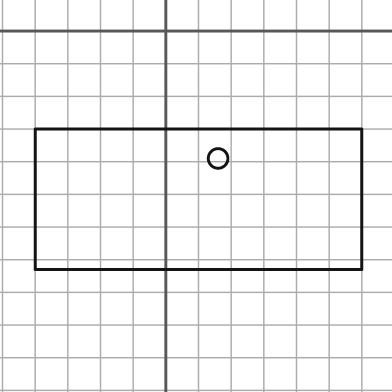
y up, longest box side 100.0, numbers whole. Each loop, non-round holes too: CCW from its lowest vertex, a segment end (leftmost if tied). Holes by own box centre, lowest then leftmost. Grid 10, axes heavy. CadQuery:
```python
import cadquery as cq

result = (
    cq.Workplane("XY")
    .moveTo(-40.0, -73.0)
    .lineTo(60.0, -73.0)
    .lineTo(60.0, -30.0)
    .lineTo(-40.0, -30.0)
    .close()
    .moveTo(16.0, -39.0)
    .circle(3.0)
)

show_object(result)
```